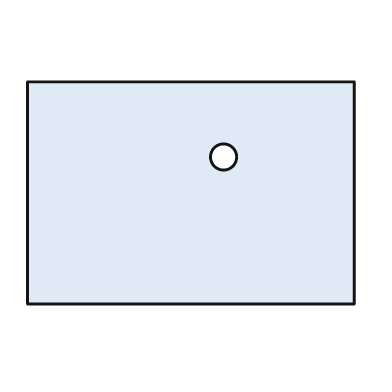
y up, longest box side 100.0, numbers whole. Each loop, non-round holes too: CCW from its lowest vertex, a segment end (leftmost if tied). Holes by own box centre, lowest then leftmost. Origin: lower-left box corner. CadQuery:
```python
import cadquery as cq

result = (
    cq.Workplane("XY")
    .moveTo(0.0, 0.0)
    .lineTo(100.0, 0.0)
    .lineTo(100.0, 68.0)
    .lineTo(0.0, 68.0)
    .close()
    .moveTo(60.0, 45.0)
    .circle(4.0)
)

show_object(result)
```